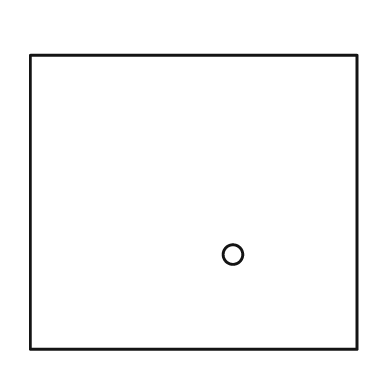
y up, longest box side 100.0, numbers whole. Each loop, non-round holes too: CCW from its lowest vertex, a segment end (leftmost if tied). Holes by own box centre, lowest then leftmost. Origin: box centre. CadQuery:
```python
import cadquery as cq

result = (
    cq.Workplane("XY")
    .moveTo(-50.0, -45.0)
    .lineTo(50.0, -45.0)
    .lineTo(50.0, 45.0)
    .lineTo(-50.0, 45.0)
    .close()
    .moveTo(12.0, -16.0)
    .circle(3.0)
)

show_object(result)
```